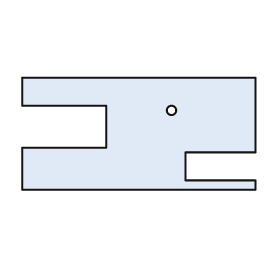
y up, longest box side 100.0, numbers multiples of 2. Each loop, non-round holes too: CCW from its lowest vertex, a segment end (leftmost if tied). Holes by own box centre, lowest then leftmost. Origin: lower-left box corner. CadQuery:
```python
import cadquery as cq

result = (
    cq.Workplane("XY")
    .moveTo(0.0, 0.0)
    .lineTo(100.0, 0.0)
    .lineTo(100.0, 4.0)
    .lineTo(70.0, 4.0)
    .lineTo(70.0, 16.0)
    .lineTo(100.0, 16.0)
    .lineTo(100.0, 48.0)
    .lineTo(0.0, 48.0)
    .lineTo(0.0, 36.0)
    .lineTo(36.0, 36.0)
    .lineTo(36.0, 18.0)
    .lineTo(0.0, 18.0)
    .close()
    .moveTo(64.0, 34.0)
    .circle(2.0)
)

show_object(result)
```